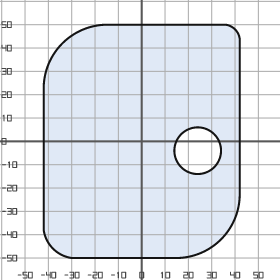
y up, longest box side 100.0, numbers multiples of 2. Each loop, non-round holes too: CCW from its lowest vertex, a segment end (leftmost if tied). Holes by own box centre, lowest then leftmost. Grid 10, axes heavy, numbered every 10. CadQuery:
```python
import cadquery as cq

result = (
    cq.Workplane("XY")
    .moveTo(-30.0, -50.0)
    .lineTo(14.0, -50.0)
    .threePointArc((34.0, -42.0), (42.0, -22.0))
    .lineTo(42.0, 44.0)
    .threePointArc((40.0, 48.0), (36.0, 50.0))
    .lineTo(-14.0, 50.0)
    .threePointArc((-34.0, 42.0), (-42.0, 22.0))
    .lineTo(-42.0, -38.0)
    .threePointArc((-38.0, -46.0), (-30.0, -50.0))
    .close()
    .moveTo(24.0, -4.0)
    .circle(10.0)
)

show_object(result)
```